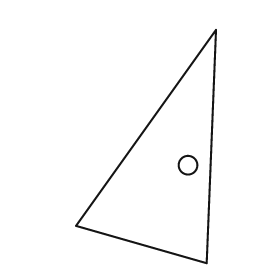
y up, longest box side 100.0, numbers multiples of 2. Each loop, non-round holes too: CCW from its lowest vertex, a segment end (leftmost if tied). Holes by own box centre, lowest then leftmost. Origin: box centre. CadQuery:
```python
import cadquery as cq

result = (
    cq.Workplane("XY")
    .moveTo(26.0, -50.0)
    .lineTo(30.0, 50.0)
    .lineTo(-30.0, -34.0)
    .close()
    .moveTo(18.0, -8.0)
    .circle(4.0)
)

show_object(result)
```